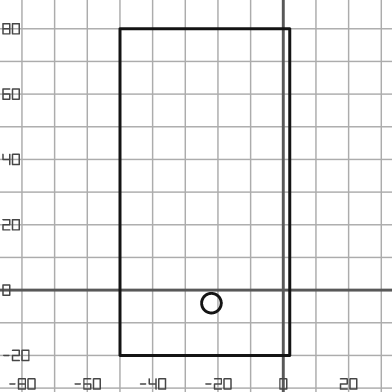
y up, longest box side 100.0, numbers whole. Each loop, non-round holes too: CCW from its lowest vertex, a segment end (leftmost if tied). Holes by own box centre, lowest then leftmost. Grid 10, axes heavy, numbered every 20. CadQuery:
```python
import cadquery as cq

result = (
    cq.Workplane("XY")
    .moveTo(-50.0, -20.0)
    .lineTo(2.0, -20.0)
    .lineTo(2.0, 80.0)
    .lineTo(-50.0, 80.0)
    .close()
    .moveTo(-22.0, -4.0)
    .circle(3.0)
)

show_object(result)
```